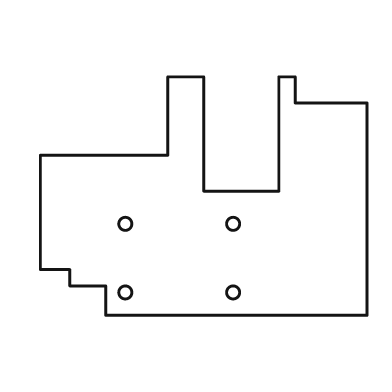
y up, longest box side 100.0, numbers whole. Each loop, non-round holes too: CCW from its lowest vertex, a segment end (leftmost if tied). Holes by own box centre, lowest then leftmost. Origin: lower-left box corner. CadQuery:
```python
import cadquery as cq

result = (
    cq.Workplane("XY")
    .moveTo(20.0, 0.0)
    .lineTo(100.0, 0.0)
    .lineTo(100.0, 65.0)
    .lineTo(78.0, 65.0)
    .lineTo(78.0, 73.0)
    .lineTo(73.0, 73.0)
    .lineTo(73.0, 38.0)
    .lineTo(50.0, 38.0)
    .lineTo(50.0, 73.0)
    .lineTo(39.0, 73.0)
    .lineTo(39.0, 49.0)
    .lineTo(0.0, 49.0)
    .lineTo(0.0, 14.0)
    .lineTo(9.0, 14.0)
    .lineTo(9.0, 9.0)
    .lineTo(20.0, 9.0)
    .close()
    .moveTo(26.0, 7.0)
    .circle(2.0)
    .moveTo(59.0, 7.0)
    .circle(2.0)
    .moveTo(26.0, 28.0)
    .circle(2.0)
    .moveTo(59.0, 28.0)
    .circle(2.0)
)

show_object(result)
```